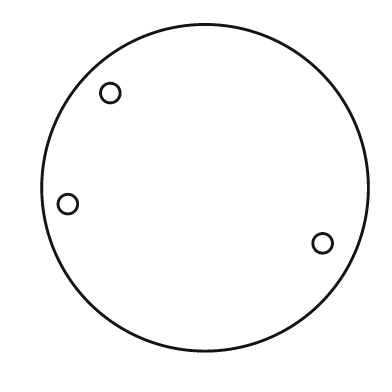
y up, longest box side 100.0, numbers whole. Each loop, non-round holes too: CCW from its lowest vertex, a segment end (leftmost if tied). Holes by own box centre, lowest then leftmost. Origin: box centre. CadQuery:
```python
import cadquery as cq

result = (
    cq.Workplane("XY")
    .moveTo(0.0, 0.0)
    .circle(50.0)
    .moveTo(36.0, -17.0)
    .circle(3.0)
    .moveTo(-42.0, -5.0)
    .circle(3.0)
    .moveTo(-29.0, 29.0)
    .circle(3.0)
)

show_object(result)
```